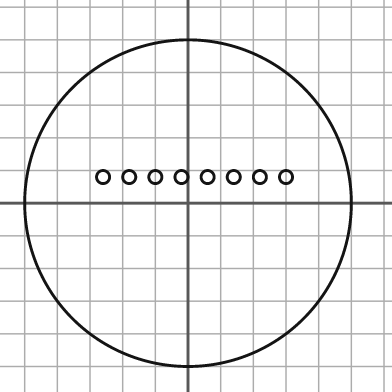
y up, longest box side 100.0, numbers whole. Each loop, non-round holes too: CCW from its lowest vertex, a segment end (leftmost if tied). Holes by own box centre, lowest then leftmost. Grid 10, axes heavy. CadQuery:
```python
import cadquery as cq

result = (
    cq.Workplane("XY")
    .moveTo(0.0, 0.0)
    .circle(50.0)
    .moveTo(-26.0, 8.0)
    .circle(2.0)
    .moveTo(-18.0, 8.0)
    .circle(2.0)
    .moveTo(-10.0, 8.0)
    .circle(2.0)
    .moveTo(-2.0, 8.0)
    .circle(2.0)
    .moveTo(6.0, 8.0)
    .circle(2.0)
    .moveTo(14.0, 8.0)
    .circle(2.0)
    .moveTo(22.0, 8.0)
    .circle(2.0)
    .moveTo(30.0, 8.0)
    .circle(2.0)
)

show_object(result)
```